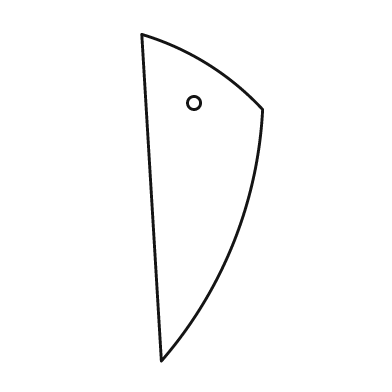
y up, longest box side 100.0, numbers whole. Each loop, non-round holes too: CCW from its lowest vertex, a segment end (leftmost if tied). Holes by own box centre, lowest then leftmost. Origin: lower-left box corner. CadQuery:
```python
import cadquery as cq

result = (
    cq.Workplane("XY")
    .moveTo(6.0, 0.0)
    .threePointArc((28.0, 36.0), (37.0, 77.0))
    .threePointArc((20.0, 91.0), (0.0, 100.0))
    .close()
    .moveTo(16.0, 79.0)
    .circle(2.0)
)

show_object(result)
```